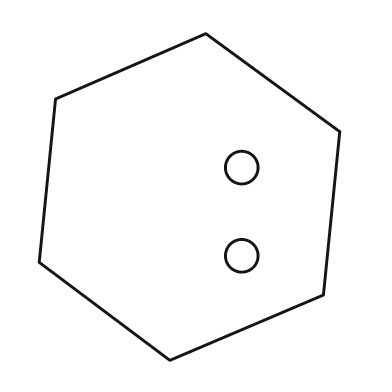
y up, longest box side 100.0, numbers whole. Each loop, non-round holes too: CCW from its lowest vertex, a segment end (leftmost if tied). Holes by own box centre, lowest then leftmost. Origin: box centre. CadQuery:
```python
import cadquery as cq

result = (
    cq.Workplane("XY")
    .moveTo(-6.0, -50.0)
    .lineTo(41.0, -30.0)
    .lineTo(46.0, 20.0)
    .lineTo(5.0, 50.0)
    .lineTo(-41.0, 30.0)
    .lineTo(-46.0, -20.0)
    .close()
    .moveTo(16.0, -18.0)
    .circle(5.0)
    .moveTo(16.0, 9.0)
    .circle(5.0)
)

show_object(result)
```